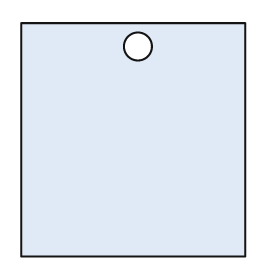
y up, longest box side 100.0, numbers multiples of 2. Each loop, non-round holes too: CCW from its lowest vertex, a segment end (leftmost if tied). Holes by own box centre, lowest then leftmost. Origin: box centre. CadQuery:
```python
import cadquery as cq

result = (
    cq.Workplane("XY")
    .moveTo(-48.0, -50.0)
    .lineTo(48.0, -50.0)
    .lineTo(48.0, 50.0)
    .lineTo(-48.0, 50.0)
    .close()
    .moveTo(2.0, 40.0)
    .circle(6.0)
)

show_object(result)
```